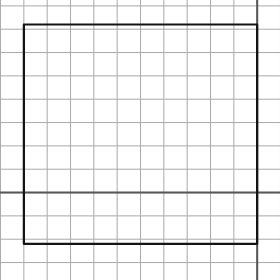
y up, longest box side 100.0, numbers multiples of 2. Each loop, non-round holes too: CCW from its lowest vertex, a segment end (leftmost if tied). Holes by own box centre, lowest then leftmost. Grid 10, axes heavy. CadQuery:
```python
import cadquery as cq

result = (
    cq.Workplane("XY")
    .moveTo(-100.0, -22.0)
    .lineTo(0.0, -22.0)
    .lineTo(0.0, 72.0)
    .lineTo(-100.0, 72.0)
    .close()
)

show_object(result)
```